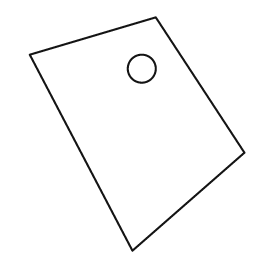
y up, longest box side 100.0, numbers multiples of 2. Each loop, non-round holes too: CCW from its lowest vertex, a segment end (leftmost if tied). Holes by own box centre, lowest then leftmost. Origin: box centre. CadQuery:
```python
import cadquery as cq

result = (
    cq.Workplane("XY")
    .moveTo(-2.0, -50.0)
    .lineTo(46.0, -8.0)
    .lineTo(8.0, 50.0)
    .lineTo(-46.0, 34.0)
    .close()
    .moveTo(2.0, 28.0)
    .circle(6.0)
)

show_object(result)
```